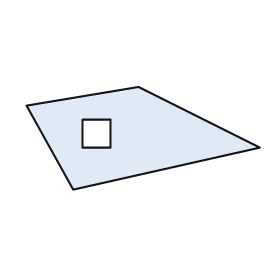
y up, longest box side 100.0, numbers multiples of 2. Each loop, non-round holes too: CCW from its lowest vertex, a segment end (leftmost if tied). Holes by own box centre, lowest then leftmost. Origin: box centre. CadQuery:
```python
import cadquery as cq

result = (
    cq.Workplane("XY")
    .moveTo(-30.0, -22.0)
    .lineTo(50.0, -4.0)
    .lineTo(-2.0, 22.0)
    .lineTo(-50.0, 14.0)
    .close()
    .moveTo(-26.0, -4.0)
    .lineTo(-14.0, -4.0)
    .lineTo(-14.0, 8.0)
    .lineTo(-26.0, 8.0)
    .close()
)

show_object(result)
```